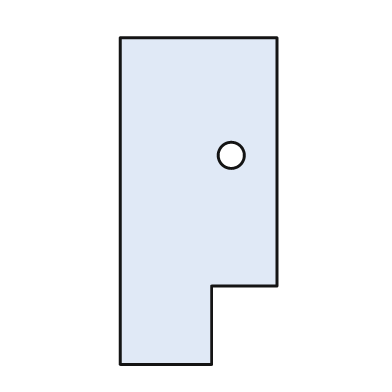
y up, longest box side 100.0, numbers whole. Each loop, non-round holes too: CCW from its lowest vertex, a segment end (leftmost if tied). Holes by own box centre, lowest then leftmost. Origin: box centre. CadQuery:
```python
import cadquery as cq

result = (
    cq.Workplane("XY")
    .moveTo(-24.0, -50.0)
    .lineTo(4.0, -50.0)
    .lineTo(4.0, -26.0)
    .lineTo(24.0, -26.0)
    .lineTo(24.0, 50.0)
    .lineTo(-24.0, 50.0)
    .close()
    .moveTo(10.0, 14.0)
    .circle(4.0)
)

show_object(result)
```